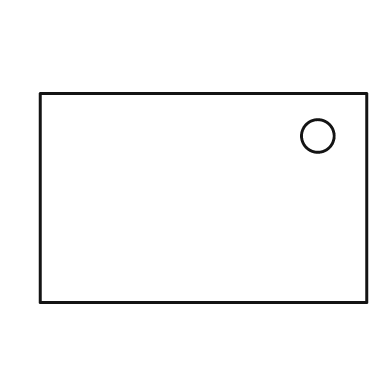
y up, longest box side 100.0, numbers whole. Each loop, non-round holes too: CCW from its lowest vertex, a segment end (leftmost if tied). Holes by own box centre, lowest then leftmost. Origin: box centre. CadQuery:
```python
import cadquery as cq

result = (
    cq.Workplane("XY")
    .moveTo(-50.0, -32.0)
    .lineTo(50.0, -32.0)
    .lineTo(50.0, 32.0)
    .lineTo(-50.0, 32.0)
    .close()
    .moveTo(35.0, 19.0)
    .circle(5.0)
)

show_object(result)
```